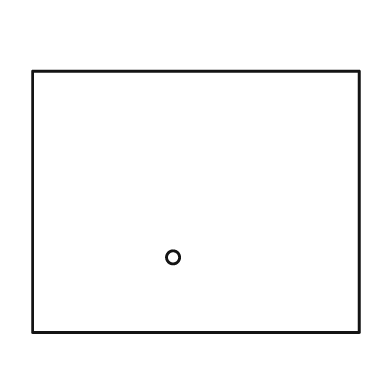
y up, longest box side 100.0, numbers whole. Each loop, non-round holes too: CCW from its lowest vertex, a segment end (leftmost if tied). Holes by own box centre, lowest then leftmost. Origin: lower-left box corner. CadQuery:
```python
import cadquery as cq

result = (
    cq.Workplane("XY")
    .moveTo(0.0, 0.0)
    .lineTo(100.0, 0.0)
    .lineTo(100.0, 80.0)
    .lineTo(0.0, 80.0)
    .close()
    .moveTo(43.0, 23.0)
    .circle(2.0)
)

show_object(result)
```